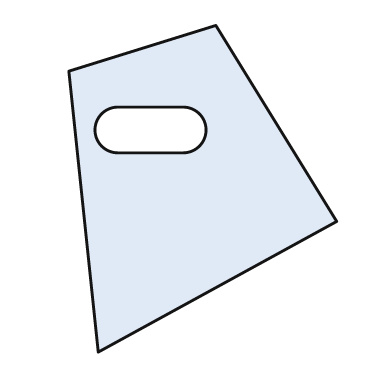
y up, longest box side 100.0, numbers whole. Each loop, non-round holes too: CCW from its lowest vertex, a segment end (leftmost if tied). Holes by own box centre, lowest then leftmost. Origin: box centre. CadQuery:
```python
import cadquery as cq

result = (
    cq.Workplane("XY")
    .moveTo(-32.0, -50.0)
    .lineTo(41.0, -10.0)
    .lineTo(4.0, 50.0)
    .lineTo(-41.0, 36.0)
    .close()
    .moveTo(-26.0, 11.0)
    .lineTo(-6.0, 11.0)
    .threePointArc((1.0, 18.0), (-6.0, 25.0))
    .lineTo(-26.0, 25.0)
    .threePointArc((-33.0, 18.0), (-26.0, 11.0))
    .close()
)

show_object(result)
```